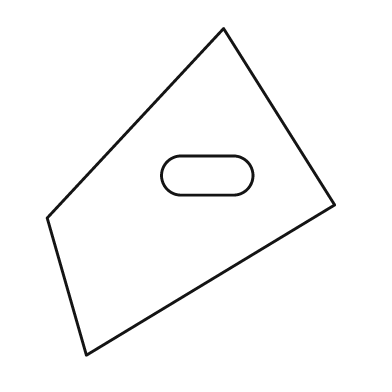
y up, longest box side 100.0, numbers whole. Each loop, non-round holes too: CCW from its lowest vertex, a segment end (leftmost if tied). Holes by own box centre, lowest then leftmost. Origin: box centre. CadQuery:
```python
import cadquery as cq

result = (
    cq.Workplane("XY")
    .moveTo(-32.0, -50.0)
    .lineTo(44.0, -4.0)
    .lineTo(10.0, 50.0)
    .lineTo(-44.0, -8.0)
    .close()
    .moveTo(-3.0, -1.0)
    .lineTo(13.0, -1.0)
    .threePointArc((19.0, 5.0), (13.0, 11.0))
    .lineTo(-3.0, 11.0)
    .threePointArc((-9.0, 5.0), (-3.0, -1.0))
    .close()
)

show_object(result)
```